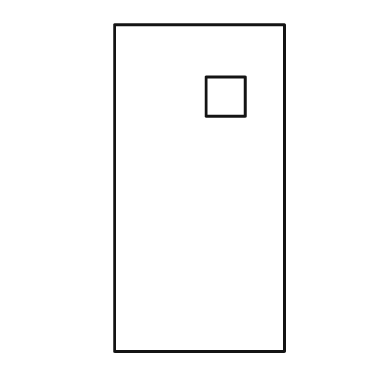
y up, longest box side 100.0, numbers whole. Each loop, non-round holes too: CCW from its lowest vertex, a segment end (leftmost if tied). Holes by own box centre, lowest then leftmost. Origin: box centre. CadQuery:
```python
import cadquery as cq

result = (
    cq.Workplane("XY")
    .moveTo(-26.0, -50.0)
    .lineTo(26.0, -50.0)
    .lineTo(26.0, 50.0)
    .lineTo(-26.0, 50.0)
    .close()
    .moveTo(2.0, 22.0)
    .lineTo(14.0, 22.0)
    .lineTo(14.0, 34.0)
    .lineTo(2.0, 34.0)
    .close()
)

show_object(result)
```